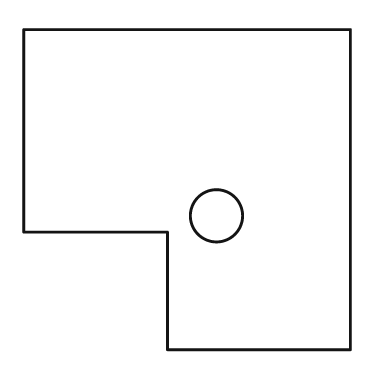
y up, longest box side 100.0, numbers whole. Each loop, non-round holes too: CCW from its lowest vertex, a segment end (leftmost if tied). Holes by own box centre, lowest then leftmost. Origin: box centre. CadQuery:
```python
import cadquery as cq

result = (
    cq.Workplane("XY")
    .moveTo(-6.0, -49.0)
    .lineTo(50.0, -49.0)
    .lineTo(50.0, 49.0)
    .lineTo(-50.0, 49.0)
    .lineTo(-50.0, -13.0)
    .lineTo(-6.0, -13.0)
    .close()
    .moveTo(9.0, -8.0)
    .circle(8.0)
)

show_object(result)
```